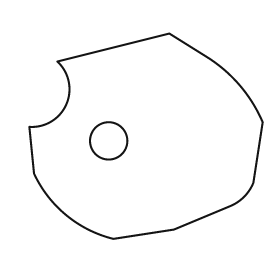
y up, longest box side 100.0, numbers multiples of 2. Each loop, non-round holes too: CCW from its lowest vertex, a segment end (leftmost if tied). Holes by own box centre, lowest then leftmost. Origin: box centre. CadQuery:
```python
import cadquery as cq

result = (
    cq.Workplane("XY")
    .moveTo(-14.0, -44.0)
    .lineTo(12.0, -40.0)
    .lineTo(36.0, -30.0)
    .threePointArc((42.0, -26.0), (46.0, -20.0))
    .lineTo(50.0, 6.0)
    .threePointArc((40.0, 22.0), (26.0, 34.0))
    .lineTo(10.0, 44.0)
    .lineTo(-38.0, 32.0)
    .threePointArc((-34.0, 14.0), (-50.0, 4.0))
    .lineTo(-48.0, -16.0)
    .threePointArc((-34.0, -34.0), (-14.0, -44.0))
    .close()
    .moveTo(-16.0, -2.0)
    .circle(8.0)
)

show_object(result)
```